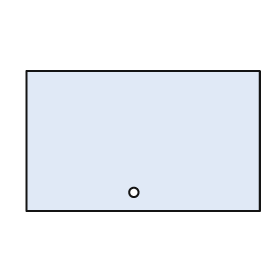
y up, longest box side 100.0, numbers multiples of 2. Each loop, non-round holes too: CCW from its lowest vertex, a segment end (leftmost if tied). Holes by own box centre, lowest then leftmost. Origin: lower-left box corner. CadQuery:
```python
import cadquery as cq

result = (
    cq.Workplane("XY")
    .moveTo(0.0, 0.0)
    .lineTo(100.0, 0.0)
    .lineTo(100.0, 60.0)
    .lineTo(0.0, 60.0)
    .close()
    .moveTo(46.0, 8.0)
    .circle(2.0)
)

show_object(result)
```